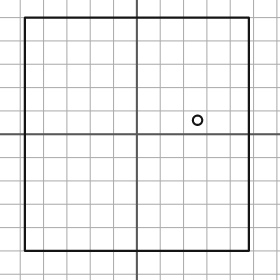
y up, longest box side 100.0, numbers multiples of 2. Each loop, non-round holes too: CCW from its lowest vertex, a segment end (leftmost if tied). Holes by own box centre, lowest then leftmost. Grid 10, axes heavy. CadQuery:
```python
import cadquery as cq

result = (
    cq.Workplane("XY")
    .moveTo(-48.0, -50.0)
    .lineTo(48.0, -50.0)
    .lineTo(48.0, 50.0)
    .lineTo(-48.0, 50.0)
    .close()
    .moveTo(26.0, 6.0)
    .circle(2.0)
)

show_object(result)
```